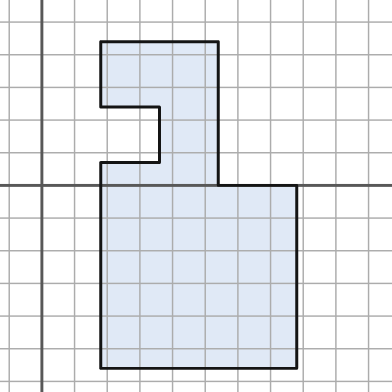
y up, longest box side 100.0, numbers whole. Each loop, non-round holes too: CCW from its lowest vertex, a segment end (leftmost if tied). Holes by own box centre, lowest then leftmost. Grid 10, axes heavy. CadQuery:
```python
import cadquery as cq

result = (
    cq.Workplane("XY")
    .moveTo(18.0, -56.0)
    .lineTo(78.0, -56.0)
    .lineTo(78.0, 0.0)
    .lineTo(54.0, 0.0)
    .lineTo(54.0, 44.0)
    .lineTo(18.0, 44.0)
    .lineTo(18.0, 24.0)
    .lineTo(36.0, 24.0)
    .lineTo(36.0, 7.0)
    .lineTo(18.0, 7.0)
    .close()
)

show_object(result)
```